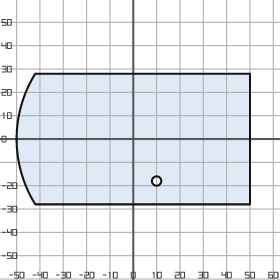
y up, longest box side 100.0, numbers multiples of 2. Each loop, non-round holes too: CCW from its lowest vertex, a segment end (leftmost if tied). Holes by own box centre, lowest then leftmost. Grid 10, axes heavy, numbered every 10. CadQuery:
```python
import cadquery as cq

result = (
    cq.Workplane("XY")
    .moveTo(-42.0, -28.0)
    .lineTo(50.0, -28.0)
    .lineTo(50.0, 28.0)
    .lineTo(-42.0, 28.0)
    .threePointArc((-50.0, 0.0), (-42.0, -28.0))
    .close()
    .moveTo(10.0, -18.0)
    .circle(2.0)
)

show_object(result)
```